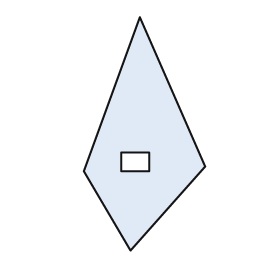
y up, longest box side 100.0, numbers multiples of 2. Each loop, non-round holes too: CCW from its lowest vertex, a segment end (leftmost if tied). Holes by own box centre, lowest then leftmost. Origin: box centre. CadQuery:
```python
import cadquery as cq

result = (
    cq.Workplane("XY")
    .moveTo(-6.0, -50.0)
    .lineTo(26.0, -14.0)
    .lineTo(-2.0, 50.0)
    .lineTo(-26.0, -16.0)
    .close()
    .moveTo(-10.0, -16.0)
    .lineTo(2.0, -16.0)
    .lineTo(2.0, -8.0)
    .lineTo(-10.0, -8.0)
    .close()
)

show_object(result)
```